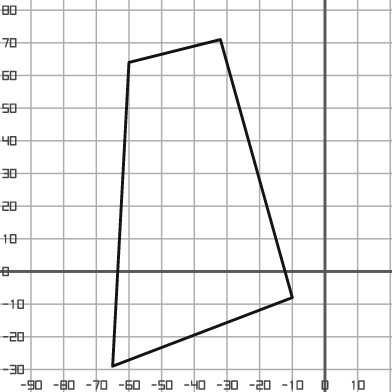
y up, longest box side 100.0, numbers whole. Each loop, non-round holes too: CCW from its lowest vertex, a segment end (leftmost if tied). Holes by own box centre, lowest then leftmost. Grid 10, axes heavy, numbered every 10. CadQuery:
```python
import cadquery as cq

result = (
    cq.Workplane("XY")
    .moveTo(-65.0, -29.0)
    .lineTo(-10.0, -8.0)
    .lineTo(-32.0, 71.0)
    .lineTo(-60.0, 64.0)
    .close()
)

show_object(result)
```